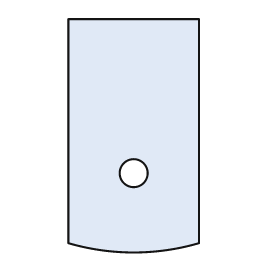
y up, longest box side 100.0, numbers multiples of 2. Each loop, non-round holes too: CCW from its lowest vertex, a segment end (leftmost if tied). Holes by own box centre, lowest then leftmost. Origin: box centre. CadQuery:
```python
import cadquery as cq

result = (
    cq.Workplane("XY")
    .moveTo(-28.0, -46.0)
    .threePointArc((0.0, -50.0), (28.0, -46.0))
    .lineTo(28.0, 50.0)
    .lineTo(-28.0, 50.0)
    .close()
    .moveTo(0.0, -16.0)
    .circle(6.0)
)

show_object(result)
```